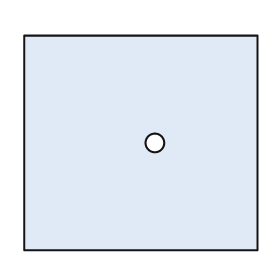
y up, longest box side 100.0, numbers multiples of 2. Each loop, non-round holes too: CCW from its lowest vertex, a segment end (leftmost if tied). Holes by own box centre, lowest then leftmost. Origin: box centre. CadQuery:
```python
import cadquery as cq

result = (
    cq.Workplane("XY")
    .moveTo(-50.0, -46.0)
    .lineTo(50.0, -46.0)
    .lineTo(50.0, 46.0)
    .lineTo(-50.0, 46.0)
    .close()
    .moveTo(6.0, 0.0)
    .circle(4.0)
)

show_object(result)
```